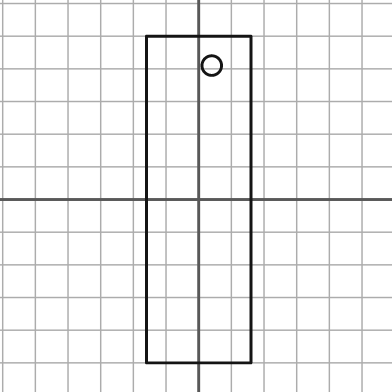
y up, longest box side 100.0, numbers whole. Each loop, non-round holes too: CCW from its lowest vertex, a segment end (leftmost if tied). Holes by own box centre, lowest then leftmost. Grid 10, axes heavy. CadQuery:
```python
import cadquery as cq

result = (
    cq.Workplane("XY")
    .moveTo(-16.0, -50.0)
    .lineTo(16.0, -50.0)
    .lineTo(16.0, 50.0)
    .lineTo(-16.0, 50.0)
    .close()
    .moveTo(4.0, 41.0)
    .circle(3.0)
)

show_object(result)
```